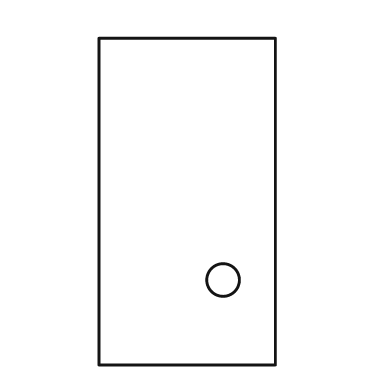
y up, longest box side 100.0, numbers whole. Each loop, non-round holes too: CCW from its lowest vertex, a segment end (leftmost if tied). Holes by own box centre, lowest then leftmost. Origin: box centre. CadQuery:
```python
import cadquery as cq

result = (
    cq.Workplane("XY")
    .moveTo(-27.0, -50.0)
    .lineTo(27.0, -50.0)
    .lineTo(27.0, 50.0)
    .lineTo(-27.0, 50.0)
    .close()
    .moveTo(11.0, -24.0)
    .circle(5.0)
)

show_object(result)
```